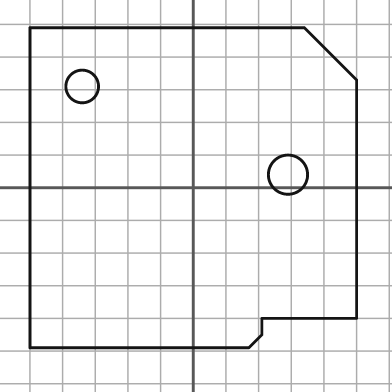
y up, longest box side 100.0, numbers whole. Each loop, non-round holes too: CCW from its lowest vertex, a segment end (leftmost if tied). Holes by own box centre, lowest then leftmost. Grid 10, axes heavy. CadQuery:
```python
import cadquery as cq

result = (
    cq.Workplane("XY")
    .moveTo(-50.0, -49.0)
    .lineTo(17.0, -49.0)
    .lineTo(21.0, -45.0)
    .lineTo(21.0, -40.0)
    .lineTo(50.0, -40.0)
    .lineTo(50.0, 33.0)
    .lineTo(34.0, 49.0)
    .lineTo(-50.0, 49.0)
    .close()
    .moveTo(29.0, 4.0)
    .circle(6.0)
    .moveTo(-34.0, 31.0)
    .circle(5.0)
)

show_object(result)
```